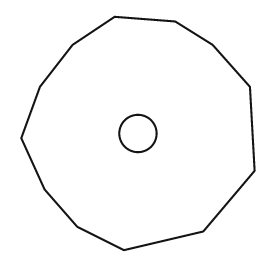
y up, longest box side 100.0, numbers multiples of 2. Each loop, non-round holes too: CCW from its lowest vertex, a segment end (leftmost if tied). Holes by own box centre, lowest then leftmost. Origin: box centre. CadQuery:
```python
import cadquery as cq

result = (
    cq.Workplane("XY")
    .moveTo(-6.0, -50.0)
    .lineTo(28.0, -42.0)
    .lineTo(50.0, -16.0)
    .lineTo(48.0, 20.0)
    .lineTo(32.0, 38.0)
    .lineTo(16.0, 48.0)
    .lineTo(-10.0, 50.0)
    .lineTo(-28.0, 38.0)
    .lineTo(-42.0, 20.0)
    .lineTo(-50.0, -2.0)
    .lineTo(-40.0, -24.0)
    .lineTo(-26.0, -40.0)
    .close()
    .moveTo(0.0, 0.0)
    .circle(8.0)
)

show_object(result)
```